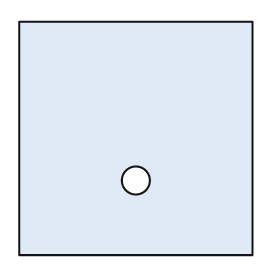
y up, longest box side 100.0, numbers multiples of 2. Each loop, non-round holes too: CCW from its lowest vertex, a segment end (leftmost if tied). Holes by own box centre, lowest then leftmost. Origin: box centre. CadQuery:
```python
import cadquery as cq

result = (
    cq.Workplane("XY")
    .moveTo(-50.0, -50.0)
    .lineTo(50.0, -50.0)
    .lineTo(50.0, 50.0)
    .lineTo(-50.0, 50.0)
    .close()
    .moveTo(0.0, -18.0)
    .circle(6.0)
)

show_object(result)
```